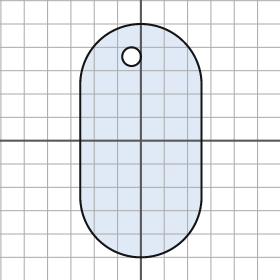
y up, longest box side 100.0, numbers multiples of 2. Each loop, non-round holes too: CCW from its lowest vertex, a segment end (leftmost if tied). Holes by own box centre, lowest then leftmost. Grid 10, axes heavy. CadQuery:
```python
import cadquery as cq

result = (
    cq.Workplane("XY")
    .moveTo(-26.0, -24.0)
    .threePointArc((0.0, -50.0), (26.0, -24.0))
    .lineTo(26.0, 24.0)
    .threePointArc((0.0, 50.0), (-26.0, 24.0))
    .close()
    .moveTo(-4.0, 36.0)
    .circle(4.0)
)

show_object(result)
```